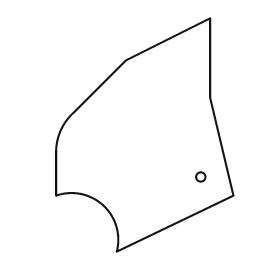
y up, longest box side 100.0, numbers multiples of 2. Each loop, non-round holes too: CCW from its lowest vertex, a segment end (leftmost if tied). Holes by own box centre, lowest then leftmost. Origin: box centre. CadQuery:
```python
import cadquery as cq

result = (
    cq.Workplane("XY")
    .moveTo(-12.0, -50.0)
    .lineTo(38.0, -26.0)
    .lineTo(28.0, 16.0)
    .lineTo(28.0, 50.0)
    .lineTo(-8.0, 32.0)
    .lineTo(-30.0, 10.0)
    .threePointArc((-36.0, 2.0), (-38.0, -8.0))
    .lineTo(-38.0, -26.0)
    .threePointArc((-18.0, -30.0), (-12.0, -50.0))
    .close()
    .moveTo(24.0, -18.0)
    .circle(2.0)
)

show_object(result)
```